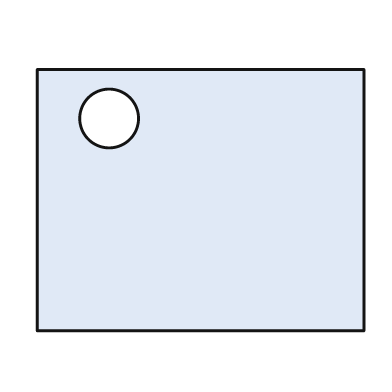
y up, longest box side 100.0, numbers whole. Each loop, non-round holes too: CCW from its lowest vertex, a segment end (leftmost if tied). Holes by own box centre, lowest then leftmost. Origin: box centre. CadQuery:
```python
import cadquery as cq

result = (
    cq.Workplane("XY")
    .moveTo(-50.0, -40.0)
    .lineTo(50.0, -40.0)
    .lineTo(50.0, 40.0)
    .lineTo(-50.0, 40.0)
    .close()
    .moveTo(-28.0, 25.0)
    .circle(9.0)
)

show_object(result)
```